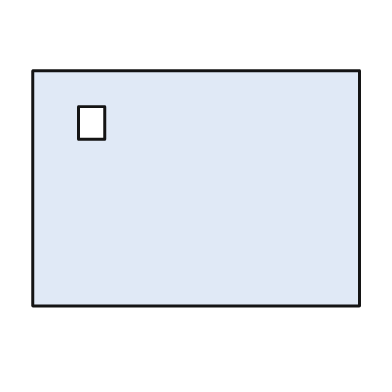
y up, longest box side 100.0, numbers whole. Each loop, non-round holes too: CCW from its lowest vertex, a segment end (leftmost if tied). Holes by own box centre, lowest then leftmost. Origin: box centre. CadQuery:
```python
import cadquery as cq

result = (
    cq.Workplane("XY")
    .moveTo(-50.0, -36.0)
    .lineTo(50.0, -36.0)
    .lineTo(50.0, 36.0)
    .lineTo(-50.0, 36.0)
    .close()
    .moveTo(-36.0, 15.0)
    .lineTo(-28.0, 15.0)
    .lineTo(-28.0, 25.0)
    .lineTo(-36.0, 25.0)
    .close()
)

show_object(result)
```